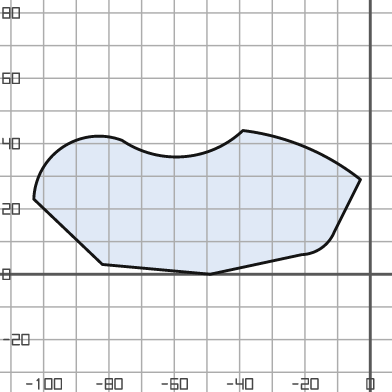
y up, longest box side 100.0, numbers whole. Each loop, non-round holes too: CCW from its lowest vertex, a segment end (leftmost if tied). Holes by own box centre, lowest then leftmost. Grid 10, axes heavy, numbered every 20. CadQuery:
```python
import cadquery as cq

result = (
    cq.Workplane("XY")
    .moveTo(-49.0, 0.0)
    .lineTo(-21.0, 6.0)
    .threePointArc((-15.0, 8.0), (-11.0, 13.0))
    .lineTo(-3.0, 29.0)
    .threePointArc((-20.0, 39.0), (-39.0, 44.0))
    .threePointArc((-57.0, 36.0), (-76.0, 41.0))
    .threePointArc((-94.0, 39.0), (-103.0, 23.0))
    .lineTo(-82.0, 3.0)
    .close()
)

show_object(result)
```